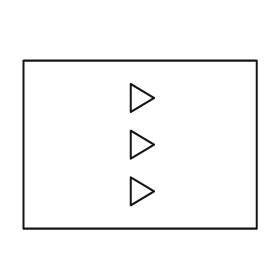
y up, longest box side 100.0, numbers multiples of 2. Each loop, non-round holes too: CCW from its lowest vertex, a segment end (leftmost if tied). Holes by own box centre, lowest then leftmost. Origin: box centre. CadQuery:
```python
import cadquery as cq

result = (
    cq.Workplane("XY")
    .moveTo(-50.0, -36.0)
    .lineTo(50.0, -36.0)
    .lineTo(50.0, 36.0)
    .lineTo(-50.0, 36.0)
    .close()
    .moveTo(-4.0, -26.0)
    .lineTo(6.0, -20.0)
    .lineTo(-4.0, -14.0)
    .close()
    .moveTo(-4.0, -6.0)
    .lineTo(6.0, 0.0)
    .lineTo(-4.0, 6.0)
    .close()
    .moveTo(-4.0, 14.0)
    .lineTo(6.0, 20.0)
    .lineTo(-4.0, 26.0)
    .close()
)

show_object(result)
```